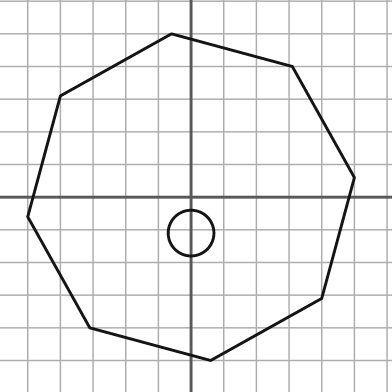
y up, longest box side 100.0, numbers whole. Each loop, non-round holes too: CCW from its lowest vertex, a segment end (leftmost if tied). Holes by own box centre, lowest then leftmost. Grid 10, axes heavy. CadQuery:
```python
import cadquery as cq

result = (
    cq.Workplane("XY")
    .moveTo(6.0, -50.0)
    .lineTo(40.0, -31.0)
    .lineTo(50.0, 6.0)
    .lineTo(31.0, 40.0)
    .lineTo(-6.0, 50.0)
    .lineTo(-40.0, 31.0)
    .lineTo(-50.0, -6.0)
    .lineTo(-31.0, -40.0)
    .close()
    .moveTo(0.0, -11.0)
    .circle(7.0)
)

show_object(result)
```